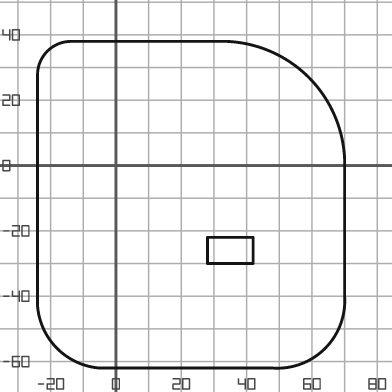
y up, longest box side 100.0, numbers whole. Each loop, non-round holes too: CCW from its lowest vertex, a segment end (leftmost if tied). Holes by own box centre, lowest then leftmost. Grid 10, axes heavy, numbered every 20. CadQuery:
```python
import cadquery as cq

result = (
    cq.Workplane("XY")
    .moveTo(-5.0, -62.0)
    .lineTo(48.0, -62.0)
    .threePointArc((64.0, -56.0), (70.0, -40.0))
    .lineTo(70.0, 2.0)
    .threePointArc((59.0, 27.0), (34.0, 38.0))
    .lineTo(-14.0, 38.0)
    .threePointArc((-21.0, 35.0), (-24.0, 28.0))
    .lineTo(-24.0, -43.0)
    .threePointArc((-18.0, -56.0), (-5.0, -62.0))
    .close()
    .moveTo(28.0, -30.0)
    .lineTo(42.0, -30.0)
    .lineTo(42.0, -22.0)
    .lineTo(28.0, -22.0)
    .close()
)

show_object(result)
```